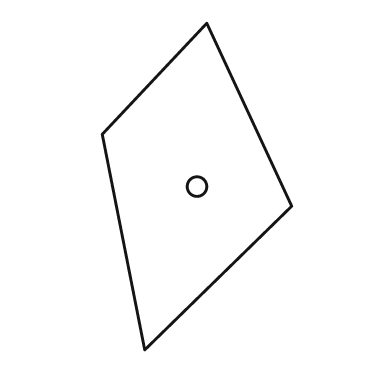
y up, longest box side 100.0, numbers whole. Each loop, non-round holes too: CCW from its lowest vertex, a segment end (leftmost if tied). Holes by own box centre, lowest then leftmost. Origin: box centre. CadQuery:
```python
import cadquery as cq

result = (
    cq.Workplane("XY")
    .moveTo(-16.0, -50.0)
    .lineTo(29.0, -6.0)
    .lineTo(3.0, 50.0)
    .lineTo(-29.0, 16.0)
    .close()
    .moveTo(0.0, 0.0)
    .circle(3.0)
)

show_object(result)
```